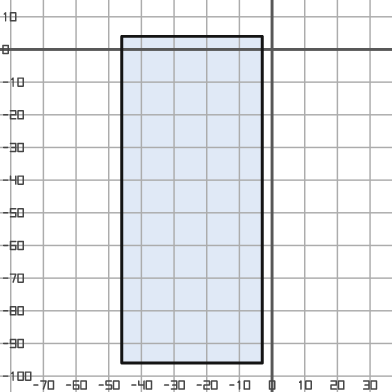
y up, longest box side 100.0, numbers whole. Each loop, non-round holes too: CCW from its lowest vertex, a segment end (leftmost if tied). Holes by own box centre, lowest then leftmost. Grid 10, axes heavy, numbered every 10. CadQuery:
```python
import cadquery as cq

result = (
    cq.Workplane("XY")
    .moveTo(-46.0, -96.0)
    .lineTo(-3.0, -96.0)
    .lineTo(-3.0, 4.0)
    .lineTo(-46.0, 4.0)
    .close()
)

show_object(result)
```